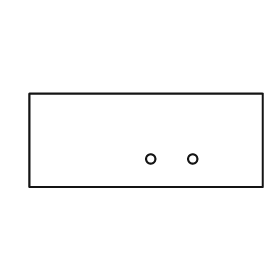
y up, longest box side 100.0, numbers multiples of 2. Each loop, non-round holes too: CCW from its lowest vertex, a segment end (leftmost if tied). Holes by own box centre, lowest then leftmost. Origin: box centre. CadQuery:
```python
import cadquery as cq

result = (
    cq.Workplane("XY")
    .moveTo(-50.0, -20.0)
    .lineTo(50.0, -20.0)
    .lineTo(50.0, 20.0)
    .lineTo(-50.0, 20.0)
    .close()
    .moveTo(2.0, -8.0)
    .circle(2.0)
    .moveTo(20.0, -8.0)
    .circle(2.0)
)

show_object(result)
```